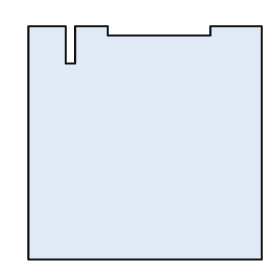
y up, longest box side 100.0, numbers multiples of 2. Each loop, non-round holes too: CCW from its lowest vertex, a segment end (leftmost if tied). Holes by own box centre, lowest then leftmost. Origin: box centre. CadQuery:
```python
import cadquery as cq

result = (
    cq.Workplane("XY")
    .moveTo(-50.0, -50.0)
    .lineTo(50.0, -50.0)
    .lineTo(50.0, 50.0)
    .lineTo(28.0, 50.0)
    .lineTo(28.0, 46.0)
    .lineTo(-16.0, 46.0)
    .lineTo(-16.0, 50.0)
    .lineTo(-30.0, 50.0)
    .lineTo(-30.0, 34.0)
    .lineTo(-34.0, 34.0)
    .lineTo(-34.0, 50.0)
    .lineTo(-50.0, 50.0)
    .close()
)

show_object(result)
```